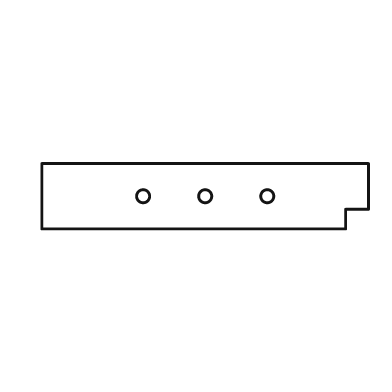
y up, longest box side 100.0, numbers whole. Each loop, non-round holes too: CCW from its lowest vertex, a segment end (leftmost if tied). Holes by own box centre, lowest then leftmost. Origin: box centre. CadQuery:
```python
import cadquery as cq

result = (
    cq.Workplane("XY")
    .moveTo(-50.0, -10.0)
    .lineTo(43.0, -10.0)
    .lineTo(43.0, -4.0)
    .lineTo(50.0, -4.0)
    .lineTo(50.0, 10.0)
    .lineTo(-50.0, 10.0)
    .close()
    .moveTo(-19.0, 0.0)
    .circle(2.0)
    .moveTo(0.0, 0.0)
    .circle(2.0)
    .moveTo(19.0, 0.0)
    .circle(2.0)
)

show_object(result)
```